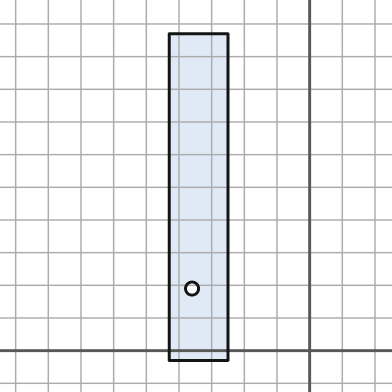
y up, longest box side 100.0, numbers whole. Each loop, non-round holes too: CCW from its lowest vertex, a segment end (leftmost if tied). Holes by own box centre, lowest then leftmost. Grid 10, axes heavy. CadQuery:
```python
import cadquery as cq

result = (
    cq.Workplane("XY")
    .moveTo(-43.0, -3.0)
    .lineTo(-25.0, -3.0)
    .lineTo(-25.0, 97.0)
    .lineTo(-43.0, 97.0)
    .close()
    .moveTo(-36.0, 19.0)
    .circle(2.0)
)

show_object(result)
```